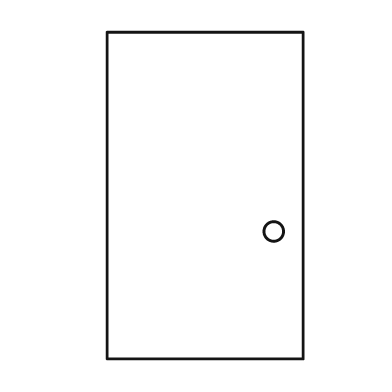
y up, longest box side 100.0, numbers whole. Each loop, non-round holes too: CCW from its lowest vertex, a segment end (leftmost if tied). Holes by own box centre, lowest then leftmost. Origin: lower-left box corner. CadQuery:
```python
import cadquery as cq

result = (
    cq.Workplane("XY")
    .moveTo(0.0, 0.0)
    .lineTo(60.0, 0.0)
    .lineTo(60.0, 100.0)
    .lineTo(0.0, 100.0)
    .close()
    .moveTo(51.0, 39.0)
    .circle(3.0)
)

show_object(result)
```